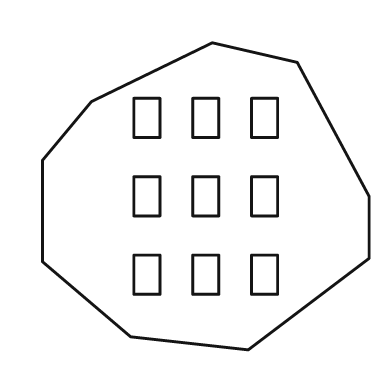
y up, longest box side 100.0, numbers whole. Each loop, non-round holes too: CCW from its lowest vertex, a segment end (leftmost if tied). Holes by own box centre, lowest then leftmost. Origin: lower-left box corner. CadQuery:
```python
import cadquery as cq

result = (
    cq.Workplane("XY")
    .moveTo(63.0, 0.0)
    .lineTo(100.0, 28.0)
    .lineTo(100.0, 47.0)
    .lineTo(78.0, 88.0)
    .lineTo(52.0, 94.0)
    .lineTo(15.0, 76.0)
    .lineTo(0.0, 58.0)
    .lineTo(0.0, 27.0)
    .lineTo(27.0, 4.0)
    .close()
    .moveTo(28.0, 17.0)
    .lineTo(36.0, 17.0)
    .lineTo(36.0, 29.0)
    .lineTo(28.0, 29.0)
    .close()
    .moveTo(46.0, 17.0)
    .lineTo(54.0, 17.0)
    .lineTo(54.0, 29.0)
    .lineTo(46.0, 29.0)
    .close()
    .moveTo(64.0, 17.0)
    .lineTo(72.0, 17.0)
    .lineTo(72.0, 29.0)
    .lineTo(64.0, 29.0)
    .close()
    .moveTo(28.0, 41.0)
    .lineTo(36.0, 41.0)
    .lineTo(36.0, 53.0)
    .lineTo(28.0, 53.0)
    .close()
    .moveTo(46.0, 41.0)
    .lineTo(54.0, 41.0)
    .lineTo(54.0, 53.0)
    .lineTo(46.0, 53.0)
    .close()
    .moveTo(64.0, 41.0)
    .lineTo(72.0, 41.0)
    .lineTo(72.0, 53.0)
    .lineTo(64.0, 53.0)
    .close()
    .moveTo(28.0, 65.0)
    .lineTo(36.0, 65.0)
    .lineTo(36.0, 77.0)
    .lineTo(28.0, 77.0)
    .close()
    .moveTo(46.0, 65.0)
    .lineTo(54.0, 65.0)
    .lineTo(54.0, 77.0)
    .lineTo(46.0, 77.0)
    .close()
    .moveTo(64.0, 65.0)
    .lineTo(72.0, 65.0)
    .lineTo(72.0, 77.0)
    .lineTo(64.0, 77.0)
    .close()
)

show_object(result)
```